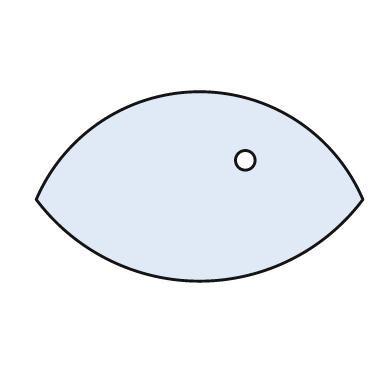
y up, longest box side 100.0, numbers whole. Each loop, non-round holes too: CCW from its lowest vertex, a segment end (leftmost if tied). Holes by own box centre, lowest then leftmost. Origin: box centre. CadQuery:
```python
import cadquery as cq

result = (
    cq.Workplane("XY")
    .moveTo(-50.0, -4.0)
    .threePointArc((0.0, -29.0), (50.0, -4.0))
    .threePointArc((0.0, 29.0), (-50.0, -4.0))
    .close()
    .moveTo(14.0, 8.0)
    .circle(3.0)
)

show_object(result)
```